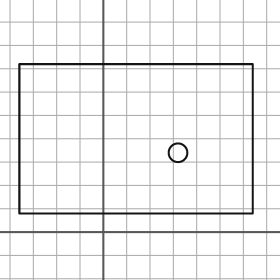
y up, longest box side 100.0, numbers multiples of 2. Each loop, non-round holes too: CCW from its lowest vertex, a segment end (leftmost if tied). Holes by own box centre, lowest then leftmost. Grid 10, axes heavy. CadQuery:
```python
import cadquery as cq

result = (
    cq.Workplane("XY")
    .moveTo(-36.0, 8.0)
    .lineTo(64.0, 8.0)
    .lineTo(64.0, 72.0)
    .lineTo(-36.0, 72.0)
    .close()
    .moveTo(32.0, 34.0)
    .circle(4.0)
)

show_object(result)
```